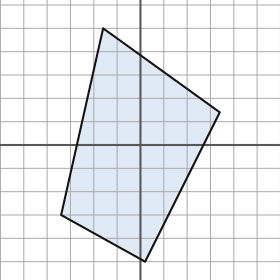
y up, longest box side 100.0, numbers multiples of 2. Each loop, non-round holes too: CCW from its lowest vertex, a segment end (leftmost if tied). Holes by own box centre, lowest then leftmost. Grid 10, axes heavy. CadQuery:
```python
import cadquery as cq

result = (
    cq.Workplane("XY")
    .moveTo(2.0, -50.0)
    .lineTo(34.0, 14.0)
    .lineTo(-16.0, 50.0)
    .lineTo(-34.0, -30.0)
    .close()
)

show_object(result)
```